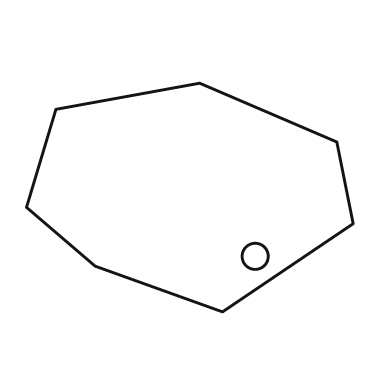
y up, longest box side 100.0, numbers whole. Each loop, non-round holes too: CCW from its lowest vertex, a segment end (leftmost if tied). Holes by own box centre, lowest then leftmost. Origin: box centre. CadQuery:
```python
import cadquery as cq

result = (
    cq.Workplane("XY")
    .moveTo(10.0, -35.0)
    .lineTo(50.0, -8.0)
    .lineTo(45.0, 17.0)
    .lineTo(3.0, 35.0)
    .lineTo(-41.0, 27.0)
    .lineTo(-50.0, -3.0)
    .lineTo(-29.0, -21.0)
    .close()
    .moveTo(20.0, -18.0)
    .circle(4.0)
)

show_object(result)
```